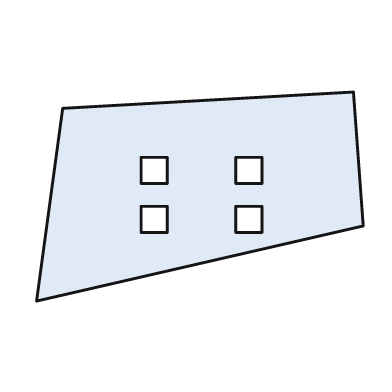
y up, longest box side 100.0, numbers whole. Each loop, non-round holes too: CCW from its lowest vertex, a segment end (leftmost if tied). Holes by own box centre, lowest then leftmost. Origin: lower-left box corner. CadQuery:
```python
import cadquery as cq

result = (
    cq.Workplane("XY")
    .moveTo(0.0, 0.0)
    .lineTo(100.0, 23.0)
    .lineTo(97.0, 64.0)
    .lineTo(8.0, 59.0)
    .close()
    .moveTo(32.0, 21.0)
    .lineTo(40.0, 21.0)
    .lineTo(40.0, 29.0)
    .lineTo(32.0, 29.0)
    .close()
    .moveTo(61.0, 21.0)
    .lineTo(69.0, 21.0)
    .lineTo(69.0, 29.0)
    .lineTo(61.0, 29.0)
    .close()
    .moveTo(32.0, 36.0)
    .lineTo(40.0, 36.0)
    .lineTo(40.0, 44.0)
    .lineTo(32.0, 44.0)
    .close()
    .moveTo(61.0, 36.0)
    .lineTo(69.0, 36.0)
    .lineTo(69.0, 44.0)
    .lineTo(61.0, 44.0)
    .close()
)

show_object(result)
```